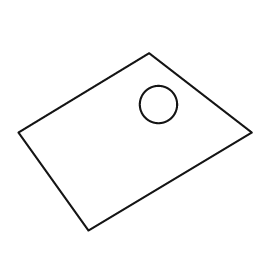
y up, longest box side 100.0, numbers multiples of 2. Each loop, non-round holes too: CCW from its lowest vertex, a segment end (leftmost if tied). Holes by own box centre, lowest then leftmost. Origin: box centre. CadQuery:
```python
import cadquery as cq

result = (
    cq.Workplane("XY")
    .moveTo(-20.0, -38.0)
    .lineTo(50.0, 4.0)
    .lineTo(6.0, 38.0)
    .lineTo(-50.0, 4.0)
    .close()
    .moveTo(10.0, 16.0)
    .circle(8.0)
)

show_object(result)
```